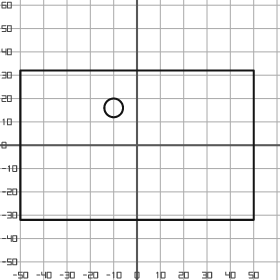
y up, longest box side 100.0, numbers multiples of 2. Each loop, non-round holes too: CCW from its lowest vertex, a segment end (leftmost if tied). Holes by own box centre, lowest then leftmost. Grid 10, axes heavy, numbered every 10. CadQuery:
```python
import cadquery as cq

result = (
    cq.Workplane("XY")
    .moveTo(-50.0, -32.0)
    .lineTo(50.0, -32.0)
    .lineTo(50.0, 32.0)
    .lineTo(-50.0, 32.0)
    .close()
    .moveTo(-10.0, 16.0)
    .circle(4.0)
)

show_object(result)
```